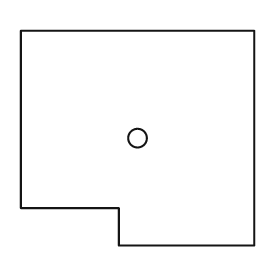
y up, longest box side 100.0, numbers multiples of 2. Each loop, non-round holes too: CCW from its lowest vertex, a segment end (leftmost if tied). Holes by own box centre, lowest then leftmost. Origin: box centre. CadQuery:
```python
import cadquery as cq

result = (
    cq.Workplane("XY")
    .moveTo(-8.0, -46.0)
    .lineTo(50.0, -46.0)
    .lineTo(50.0, 46.0)
    .lineTo(-50.0, 46.0)
    .lineTo(-50.0, -30.0)
    .lineTo(-8.0, -30.0)
    .close()
    .moveTo(0.0, 0.0)
    .circle(4.0)
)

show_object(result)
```